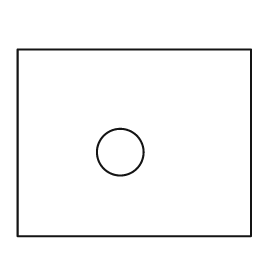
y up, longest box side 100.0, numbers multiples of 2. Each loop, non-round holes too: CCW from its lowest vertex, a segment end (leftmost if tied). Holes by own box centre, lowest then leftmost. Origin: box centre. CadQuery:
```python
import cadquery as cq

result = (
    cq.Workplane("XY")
    .moveTo(-50.0, -40.0)
    .lineTo(50.0, -40.0)
    .lineTo(50.0, 40.0)
    .lineTo(-50.0, 40.0)
    .close()
    .moveTo(-6.0, -4.0)
    .circle(10.0)
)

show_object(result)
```